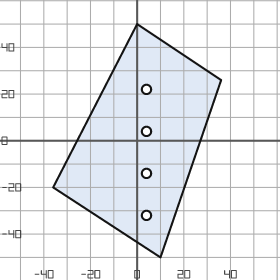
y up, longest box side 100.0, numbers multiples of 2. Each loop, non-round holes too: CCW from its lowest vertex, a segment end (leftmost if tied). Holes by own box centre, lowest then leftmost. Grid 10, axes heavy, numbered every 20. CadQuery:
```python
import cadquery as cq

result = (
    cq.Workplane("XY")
    .moveTo(10.0, -50.0)
    .lineTo(36.0, 26.0)
    .lineTo(0.0, 50.0)
    .lineTo(-36.0, -20.0)
    .close()
    .moveTo(4.0, -32.0)
    .circle(2.0)
    .moveTo(4.0, -14.0)
    .circle(2.0)
    .moveTo(4.0, 4.0)
    .circle(2.0)
    .moveTo(4.0, 22.0)
    .circle(2.0)
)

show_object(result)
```